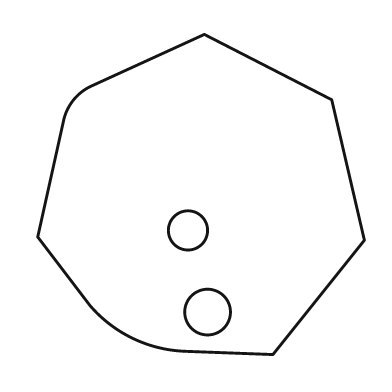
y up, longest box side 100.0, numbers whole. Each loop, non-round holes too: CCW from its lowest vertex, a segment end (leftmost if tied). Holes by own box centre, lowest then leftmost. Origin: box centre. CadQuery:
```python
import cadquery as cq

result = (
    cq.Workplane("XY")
    .moveTo(22.0, -49.0)
    .lineTo(50.0, -14.0)
    .lineTo(40.0, 29.0)
    .lineTo(1.0, 49.0)
    .lineTo(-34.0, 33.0)
    .threePointArc((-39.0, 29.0), (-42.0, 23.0))
    .lineTo(-50.0, -13.0)
    .lineTo(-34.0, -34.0)
    .threePointArc((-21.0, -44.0), (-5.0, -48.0))
    .close()
    .moveTo(2.0, -36.0)
    .circle(7.0)
    .moveTo(-4.0, -11.0)
    .circle(6.0)
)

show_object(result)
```